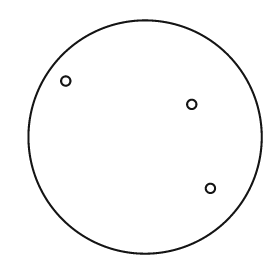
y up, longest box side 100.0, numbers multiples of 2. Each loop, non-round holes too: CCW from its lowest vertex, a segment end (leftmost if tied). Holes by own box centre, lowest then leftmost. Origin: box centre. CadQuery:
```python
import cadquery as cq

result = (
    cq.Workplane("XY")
    .moveTo(0.0, 0.0)
    .circle(50.0)
    .moveTo(28.0, -22.0)
    .circle(2.0)
    .moveTo(20.0, 14.0)
    .circle(2.0)
    .moveTo(-34.0, 24.0)
    .circle(2.0)
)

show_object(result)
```